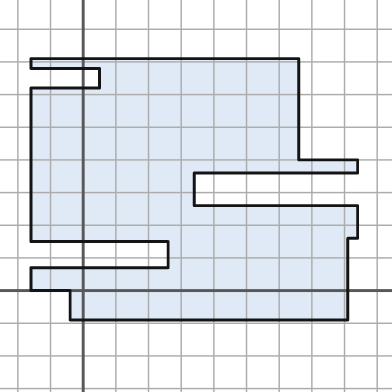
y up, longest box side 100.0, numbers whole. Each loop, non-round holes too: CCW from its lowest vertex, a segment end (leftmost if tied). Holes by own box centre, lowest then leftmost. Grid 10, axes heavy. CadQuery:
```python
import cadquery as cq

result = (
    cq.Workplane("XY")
    .moveTo(-4.0, -9.0)
    .lineTo(81.0, -9.0)
    .lineTo(81.0, 16.0)
    .lineTo(84.0, 16.0)
    .lineTo(84.0, 26.0)
    .lineTo(34.0, 26.0)
    .lineTo(34.0, 36.0)
    .lineTo(84.0, 36.0)
    .lineTo(84.0, 40.0)
    .lineTo(66.0, 40.0)
    .lineTo(66.0, 71.0)
    .lineTo(-16.0, 71.0)
    .lineTo(-16.0, 68.0)
    .lineTo(5.0, 68.0)
    .lineTo(5.0, 62.0)
    .lineTo(-16.0, 62.0)
    .lineTo(-16.0, 15.0)
    .lineTo(26.0, 15.0)
    .lineTo(26.0, 7.0)
    .lineTo(-16.0, 7.0)
    .lineTo(-16.0, 0.0)
    .lineTo(-4.0, 0.0)
    .close()
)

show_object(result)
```